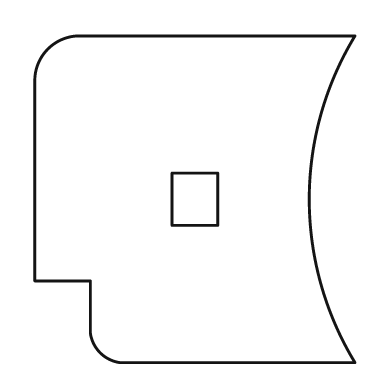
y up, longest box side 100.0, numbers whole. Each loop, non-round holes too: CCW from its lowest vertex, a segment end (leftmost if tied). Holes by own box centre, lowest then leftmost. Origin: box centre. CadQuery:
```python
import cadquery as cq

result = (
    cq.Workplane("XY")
    .moveTo(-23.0, -50.0)
    .lineTo(49.0, -50.0)
    .threePointArc((35.0, 0.0), (49.0, 50.0))
    .lineTo(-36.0, 50.0)
    .threePointArc((-45.0, 46.0), (-49.0, 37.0))
    .lineTo(-49.0, -25.0)
    .lineTo(-32.0, -25.0)
    .lineTo(-32.0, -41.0)
    .threePointArc((-29.0, -47.0), (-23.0, -50.0))
    .close()
    .moveTo(-7.0, -8.0)
    .lineTo(7.0, -8.0)
    .lineTo(7.0, 8.0)
    .lineTo(-7.0, 8.0)
    .close()
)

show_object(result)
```